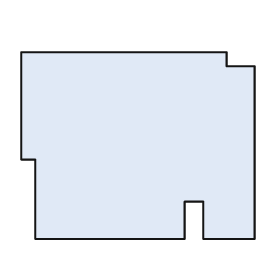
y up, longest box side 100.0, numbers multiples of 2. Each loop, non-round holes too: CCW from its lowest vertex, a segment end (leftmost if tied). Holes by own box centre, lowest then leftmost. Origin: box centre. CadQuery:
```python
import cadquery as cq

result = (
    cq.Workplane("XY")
    .moveTo(-44.0, -40.0)
    .lineTo(20.0, -40.0)
    .lineTo(20.0, -24.0)
    .lineTo(28.0, -24.0)
    .lineTo(28.0, -40.0)
    .lineTo(50.0, -40.0)
    .lineTo(50.0, 34.0)
    .lineTo(38.0, 34.0)
    .lineTo(38.0, 40.0)
    .lineTo(-50.0, 40.0)
    .lineTo(-50.0, -6.0)
    .lineTo(-44.0, -6.0)
    .close()
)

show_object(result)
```